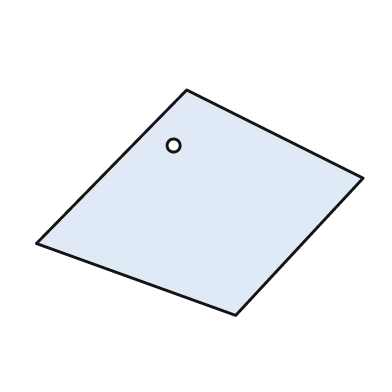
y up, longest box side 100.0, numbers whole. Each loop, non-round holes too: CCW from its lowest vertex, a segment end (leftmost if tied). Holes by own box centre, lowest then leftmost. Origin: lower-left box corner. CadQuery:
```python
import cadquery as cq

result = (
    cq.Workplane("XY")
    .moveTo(61.0, 0.0)
    .lineTo(100.0, 42.0)
    .lineTo(46.0, 69.0)
    .lineTo(0.0, 22.0)
    .close()
    .moveTo(42.0, 52.0)
    .circle(2.0)
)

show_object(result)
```